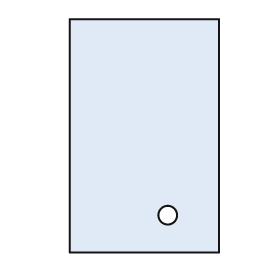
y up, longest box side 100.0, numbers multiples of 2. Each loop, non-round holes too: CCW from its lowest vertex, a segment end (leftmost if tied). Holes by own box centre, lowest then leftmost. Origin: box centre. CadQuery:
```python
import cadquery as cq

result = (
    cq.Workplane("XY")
    .moveTo(-32.0, -50.0)
    .lineTo(32.0, -50.0)
    .lineTo(32.0, 50.0)
    .lineTo(-32.0, 50.0)
    .close()
    .moveTo(10.0, -34.0)
    .circle(4.0)
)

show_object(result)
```